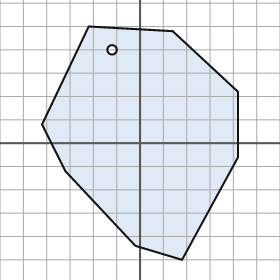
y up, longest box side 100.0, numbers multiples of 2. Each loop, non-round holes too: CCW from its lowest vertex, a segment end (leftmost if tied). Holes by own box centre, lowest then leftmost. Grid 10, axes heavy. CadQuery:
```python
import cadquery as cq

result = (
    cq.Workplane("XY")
    .moveTo(18.0, -50.0)
    .lineTo(42.0, -6.0)
    .lineTo(42.0, 22.0)
    .lineTo(14.0, 48.0)
    .lineTo(-22.0, 50.0)
    .lineTo(-42.0, 8.0)
    .lineTo(-32.0, -12.0)
    .lineTo(-2.0, -44.0)
    .close()
    .moveTo(-12.0, 40.0)
    .circle(2.0)
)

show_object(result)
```